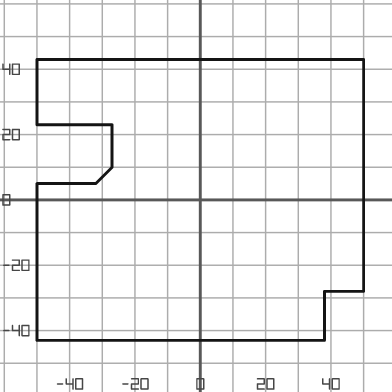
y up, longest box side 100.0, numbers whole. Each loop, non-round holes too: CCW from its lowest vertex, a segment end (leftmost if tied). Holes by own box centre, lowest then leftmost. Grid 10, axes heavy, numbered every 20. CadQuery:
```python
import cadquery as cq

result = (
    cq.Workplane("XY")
    .moveTo(-50.0, -43.0)
    .lineTo(38.0, -43.0)
    .lineTo(38.0, -28.0)
    .lineTo(50.0, -28.0)
    .lineTo(50.0, 43.0)
    .lineTo(-50.0, 43.0)
    .lineTo(-50.0, 23.0)
    .lineTo(-27.0, 23.0)
    .lineTo(-27.0, 10.0)
    .lineTo(-32.0, 5.0)
    .lineTo(-50.0, 5.0)
    .close()
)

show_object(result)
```